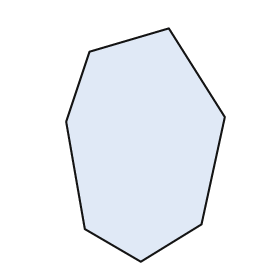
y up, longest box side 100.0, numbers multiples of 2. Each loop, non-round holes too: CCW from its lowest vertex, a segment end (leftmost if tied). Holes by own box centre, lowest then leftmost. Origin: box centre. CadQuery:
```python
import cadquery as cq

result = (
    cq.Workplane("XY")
    .moveTo(-2.0, -50.0)
    .lineTo(24.0, -34.0)
    .lineTo(34.0, 12.0)
    .lineTo(10.0, 50.0)
    .lineTo(-24.0, 40.0)
    .lineTo(-34.0, 10.0)
    .lineTo(-26.0, -36.0)
    .close()
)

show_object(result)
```